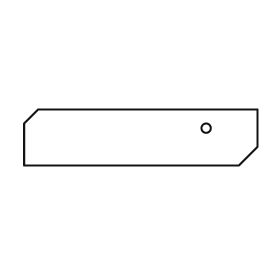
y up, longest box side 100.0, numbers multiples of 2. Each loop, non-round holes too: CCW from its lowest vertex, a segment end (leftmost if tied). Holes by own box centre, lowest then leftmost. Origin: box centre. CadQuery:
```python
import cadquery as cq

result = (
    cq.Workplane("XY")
    .moveTo(-50.0, -12.0)
    .lineTo(42.0, -12.0)
    .lineTo(50.0, -4.0)
    .lineTo(50.0, 12.0)
    .lineTo(-44.0, 12.0)
    .lineTo(-50.0, 6.0)
    .close()
    .moveTo(28.0, 4.0)
    .circle(2.0)
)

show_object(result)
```